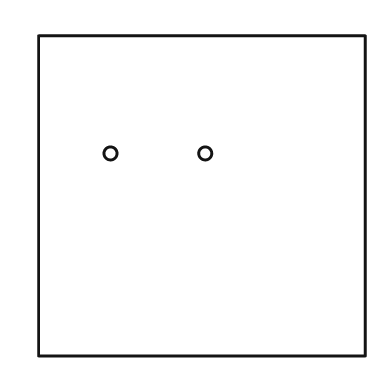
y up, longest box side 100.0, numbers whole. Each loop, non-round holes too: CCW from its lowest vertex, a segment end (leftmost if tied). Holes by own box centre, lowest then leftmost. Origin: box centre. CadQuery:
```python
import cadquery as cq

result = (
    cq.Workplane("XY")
    .moveTo(-50.0, -49.0)
    .lineTo(50.0, -49.0)
    .lineTo(50.0, 49.0)
    .lineTo(-50.0, 49.0)
    .close()
    .moveTo(-28.0, 13.0)
    .circle(2.0)
    .moveTo(1.0, 13.0)
    .circle(2.0)
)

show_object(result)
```